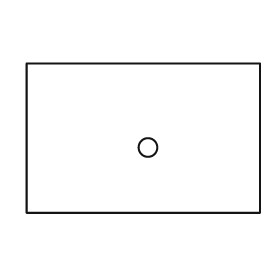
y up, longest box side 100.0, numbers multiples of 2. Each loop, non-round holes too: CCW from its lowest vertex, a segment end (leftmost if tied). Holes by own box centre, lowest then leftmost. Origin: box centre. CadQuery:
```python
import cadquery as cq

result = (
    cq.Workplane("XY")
    .moveTo(-50.0, -32.0)
    .lineTo(50.0, -32.0)
    .lineTo(50.0, 32.0)
    .lineTo(-50.0, 32.0)
    .close()
    .moveTo(2.0, -4.0)
    .circle(4.0)
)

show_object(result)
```